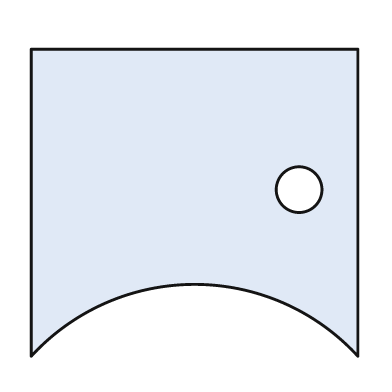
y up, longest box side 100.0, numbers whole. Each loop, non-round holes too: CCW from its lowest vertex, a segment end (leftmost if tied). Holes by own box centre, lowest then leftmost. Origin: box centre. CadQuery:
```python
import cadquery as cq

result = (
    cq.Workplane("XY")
    .moveTo(-50.0, -47.0)
    .threePointArc((0.0, -25.0), (50.0, -47.0))
    .lineTo(50.0, 47.0)
    .lineTo(-50.0, 47.0)
    .close()
    .moveTo(32.0, 4.0)
    .circle(7.0)
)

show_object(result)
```